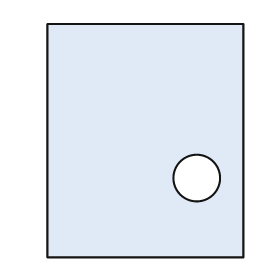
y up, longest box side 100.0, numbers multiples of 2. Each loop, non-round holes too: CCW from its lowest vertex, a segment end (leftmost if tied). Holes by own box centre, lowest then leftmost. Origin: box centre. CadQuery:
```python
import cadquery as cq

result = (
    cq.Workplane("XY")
    .moveTo(-42.0, -50.0)
    .lineTo(42.0, -50.0)
    .lineTo(42.0, 50.0)
    .lineTo(-42.0, 50.0)
    .close()
    .moveTo(22.0, -16.0)
    .circle(10.0)
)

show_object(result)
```